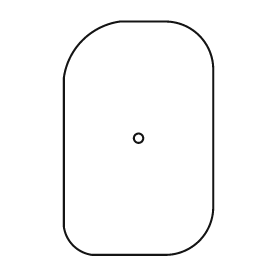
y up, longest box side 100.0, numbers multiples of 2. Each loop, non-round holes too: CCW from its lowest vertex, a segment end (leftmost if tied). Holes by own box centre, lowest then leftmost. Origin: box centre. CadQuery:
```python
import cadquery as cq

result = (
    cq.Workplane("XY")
    .moveTo(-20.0, -50.0)
    .lineTo(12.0, -50.0)
    .threePointArc((26.0, -44.0), (32.0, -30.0))
    .lineTo(32.0, 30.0)
    .threePointArc((26.0, 44.0), (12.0, 50.0))
    .lineTo(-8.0, 50.0)
    .threePointArc((-24.0, 42.0), (-32.0, 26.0))
    .lineTo(-32.0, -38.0)
    .threePointArc((-28.0, -46.0), (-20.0, -50.0))
    .close()
    .moveTo(0.0, 0.0)
    .circle(2.0)
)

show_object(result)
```